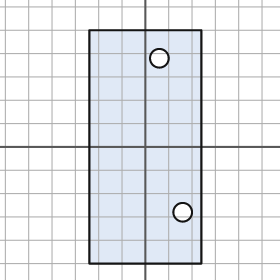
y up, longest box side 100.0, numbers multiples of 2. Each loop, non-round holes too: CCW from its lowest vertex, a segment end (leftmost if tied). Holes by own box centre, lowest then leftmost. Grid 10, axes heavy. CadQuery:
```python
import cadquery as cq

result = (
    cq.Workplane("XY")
    .moveTo(-24.0, -50.0)
    .lineTo(24.0, -50.0)
    .lineTo(24.0, 50.0)
    .lineTo(-24.0, 50.0)
    .close()
    .moveTo(16.0, -28.0)
    .circle(4.0)
    .moveTo(6.0, 38.0)
    .circle(4.0)
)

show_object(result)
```